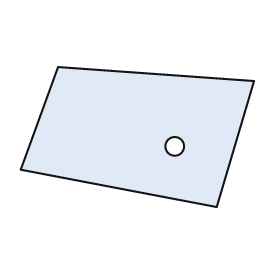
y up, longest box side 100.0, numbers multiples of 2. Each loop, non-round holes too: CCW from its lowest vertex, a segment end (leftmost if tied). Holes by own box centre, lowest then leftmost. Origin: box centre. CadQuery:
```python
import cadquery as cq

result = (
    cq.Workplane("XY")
    .moveTo(34.0, -30.0)
    .lineTo(50.0, 24.0)
    .lineTo(-34.0, 30.0)
    .lineTo(-50.0, -14.0)
    .close()
    .moveTo(16.0, -4.0)
    .circle(4.0)
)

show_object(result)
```